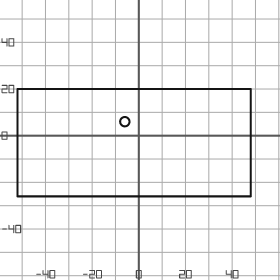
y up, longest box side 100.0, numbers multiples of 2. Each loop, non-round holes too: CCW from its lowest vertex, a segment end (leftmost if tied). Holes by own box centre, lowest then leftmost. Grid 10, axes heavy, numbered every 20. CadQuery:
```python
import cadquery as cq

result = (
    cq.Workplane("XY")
    .moveTo(-52.0, -26.0)
    .lineTo(48.0, -26.0)
    .lineTo(48.0, 20.0)
    .lineTo(-52.0, 20.0)
    .close()
    .moveTo(-6.0, 6.0)
    .circle(2.0)
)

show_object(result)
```